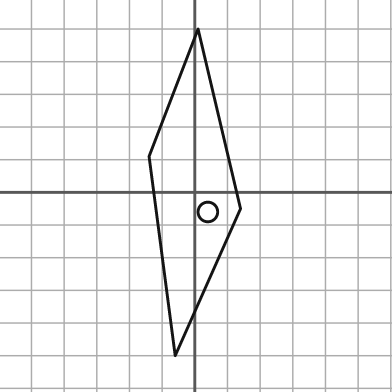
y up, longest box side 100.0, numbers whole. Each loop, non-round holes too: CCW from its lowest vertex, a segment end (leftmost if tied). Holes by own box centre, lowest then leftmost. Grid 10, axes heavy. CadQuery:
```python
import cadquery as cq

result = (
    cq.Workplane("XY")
    .moveTo(-6.0, -50.0)
    .lineTo(14.0, -5.0)
    .lineTo(1.0, 50.0)
    .lineTo(-14.0, 11.0)
    .close()
    .moveTo(4.0, -6.0)
    .circle(3.0)
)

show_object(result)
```